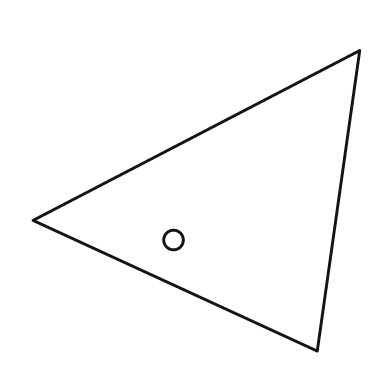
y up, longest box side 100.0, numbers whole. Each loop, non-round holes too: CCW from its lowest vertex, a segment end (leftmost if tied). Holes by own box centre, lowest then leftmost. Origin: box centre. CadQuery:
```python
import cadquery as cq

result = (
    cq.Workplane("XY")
    .moveTo(37.0, -46.0)
    .lineTo(50.0, 46.0)
    .lineTo(-50.0, -6.0)
    .close()
    .moveTo(-7.0, -12.0)
    .circle(3.0)
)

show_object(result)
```